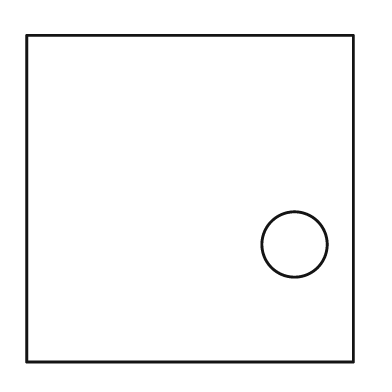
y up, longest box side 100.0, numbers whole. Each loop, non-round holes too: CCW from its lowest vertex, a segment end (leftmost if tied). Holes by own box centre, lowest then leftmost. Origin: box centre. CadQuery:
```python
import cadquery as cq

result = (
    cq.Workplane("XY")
    .moveTo(-50.0, -50.0)
    .lineTo(50.0, -50.0)
    .lineTo(50.0, 50.0)
    .lineTo(-50.0, 50.0)
    .close()
    .moveTo(32.0, -14.0)
    .circle(10.0)
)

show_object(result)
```